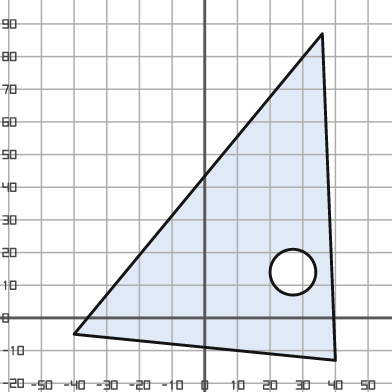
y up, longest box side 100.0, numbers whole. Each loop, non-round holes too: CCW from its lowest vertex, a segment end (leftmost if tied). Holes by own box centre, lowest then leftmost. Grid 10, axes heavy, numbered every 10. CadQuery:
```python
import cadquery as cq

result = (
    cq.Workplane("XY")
    .moveTo(40.0, -13.0)
    .lineTo(36.0, 87.0)
    .lineTo(-40.0, -5.0)
    .close()
    .moveTo(27.0, 14.0)
    .circle(7.0)
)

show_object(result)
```